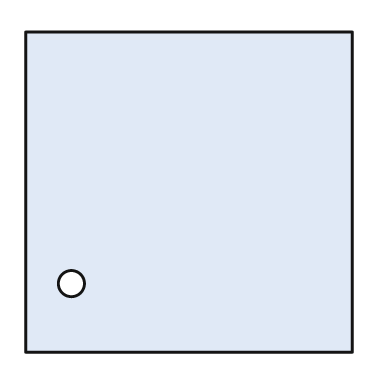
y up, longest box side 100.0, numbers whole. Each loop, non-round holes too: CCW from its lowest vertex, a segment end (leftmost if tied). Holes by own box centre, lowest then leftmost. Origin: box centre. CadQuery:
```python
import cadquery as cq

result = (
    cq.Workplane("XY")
    .moveTo(-50.0, -49.0)
    .lineTo(50.0, -49.0)
    .lineTo(50.0, 49.0)
    .lineTo(-50.0, 49.0)
    .close()
    .moveTo(-36.0, -28.0)
    .circle(4.0)
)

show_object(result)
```